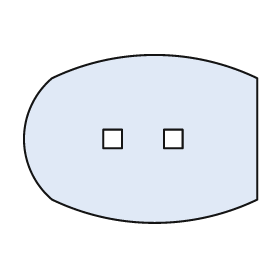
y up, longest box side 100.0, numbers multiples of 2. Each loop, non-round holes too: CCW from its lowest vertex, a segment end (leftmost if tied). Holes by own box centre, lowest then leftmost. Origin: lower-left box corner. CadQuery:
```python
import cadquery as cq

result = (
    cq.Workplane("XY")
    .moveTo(12.0, 10.0)
    .threePointArc((56.0, 0.0), (100.0, 10.0))
    .lineTo(100.0, 62.0)
    .threePointArc((56.0, 72.0), (12.0, 62.0))
    .threePointArc((0.0, 36.0), (12.0, 10.0))
    .close()
    .moveTo(34.0, 32.0)
    .lineTo(42.0, 32.0)
    .lineTo(42.0, 40.0)
    .lineTo(34.0, 40.0)
    .close()
    .moveTo(60.0, 32.0)
    .lineTo(68.0, 32.0)
    .lineTo(68.0, 40.0)
    .lineTo(60.0, 40.0)
    .close()
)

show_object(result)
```